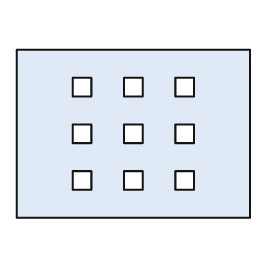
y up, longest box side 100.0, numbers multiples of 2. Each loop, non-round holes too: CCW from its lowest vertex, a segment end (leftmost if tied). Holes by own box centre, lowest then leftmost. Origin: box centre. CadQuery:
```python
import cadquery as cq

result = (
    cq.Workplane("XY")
    .moveTo(-50.0, -36.0)
    .lineTo(50.0, -36.0)
    .lineTo(50.0, 36.0)
    .lineTo(-50.0, 36.0)
    .close()
    .moveTo(-26.0, -24.0)
    .lineTo(-18.0, -24.0)
    .lineTo(-18.0, -16.0)
    .lineTo(-26.0, -16.0)
    .close()
    .moveTo(-4.0, -24.0)
    .lineTo(4.0, -24.0)
    .lineTo(4.0, -16.0)
    .lineTo(-4.0, -16.0)
    .close()
    .moveTo(18.0, -24.0)
    .lineTo(26.0, -24.0)
    .lineTo(26.0, -16.0)
    .lineTo(18.0, -16.0)
    .close()
    .moveTo(-26.0, -4.0)
    .lineTo(-18.0, -4.0)
    .lineTo(-18.0, 4.0)
    .lineTo(-26.0, 4.0)
    .close()
    .moveTo(-4.0, -4.0)
    .lineTo(4.0, -4.0)
    .lineTo(4.0, 4.0)
    .lineTo(-4.0, 4.0)
    .close()
    .moveTo(18.0, -4.0)
    .lineTo(26.0, -4.0)
    .lineTo(26.0, 4.0)
    .lineTo(18.0, 4.0)
    .close()
    .moveTo(-26.0, 16.0)
    .lineTo(-18.0, 16.0)
    .lineTo(-18.0, 24.0)
    .lineTo(-26.0, 24.0)
    .close()
    .moveTo(-4.0, 16.0)
    .lineTo(4.0, 16.0)
    .lineTo(4.0, 24.0)
    .lineTo(-4.0, 24.0)
    .close()
    .moveTo(18.0, 16.0)
    .lineTo(26.0, 16.0)
    .lineTo(26.0, 24.0)
    .lineTo(18.0, 24.0)
    .close()
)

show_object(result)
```